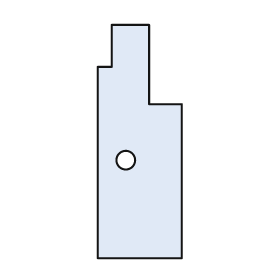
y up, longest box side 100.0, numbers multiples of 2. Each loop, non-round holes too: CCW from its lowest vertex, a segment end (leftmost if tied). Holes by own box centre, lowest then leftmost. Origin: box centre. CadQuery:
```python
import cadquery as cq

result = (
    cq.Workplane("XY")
    .moveTo(-18.0, -50.0)
    .lineTo(18.0, -50.0)
    .lineTo(18.0, 16.0)
    .lineTo(4.0, 16.0)
    .lineTo(4.0, 50.0)
    .lineTo(-12.0, 50.0)
    .lineTo(-12.0, 32.0)
    .lineTo(-18.0, 32.0)
    .close()
    .moveTo(-6.0, -8.0)
    .circle(4.0)
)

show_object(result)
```